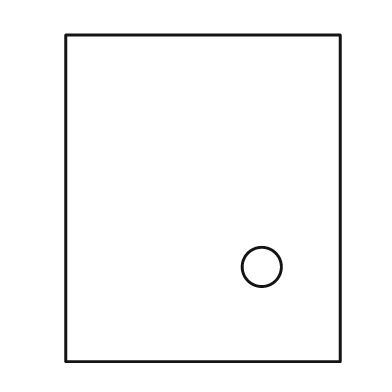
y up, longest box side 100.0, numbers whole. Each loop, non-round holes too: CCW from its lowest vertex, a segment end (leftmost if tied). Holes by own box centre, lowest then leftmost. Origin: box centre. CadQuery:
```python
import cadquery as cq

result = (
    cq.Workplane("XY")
    .moveTo(-42.0, -50.0)
    .lineTo(42.0, -50.0)
    .lineTo(42.0, 50.0)
    .lineTo(-42.0, 50.0)
    .close()
    .moveTo(18.0, -21.0)
    .circle(6.0)
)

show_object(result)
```